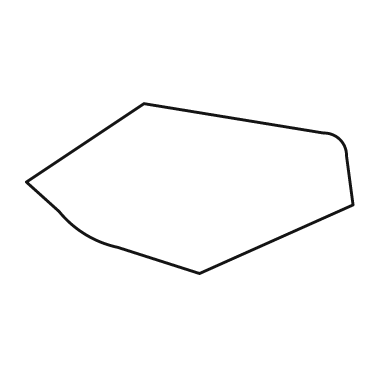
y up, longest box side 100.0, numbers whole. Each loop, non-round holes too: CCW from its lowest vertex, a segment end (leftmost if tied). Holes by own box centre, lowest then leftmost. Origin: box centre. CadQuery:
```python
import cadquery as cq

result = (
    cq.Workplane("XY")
    .moveTo(3.0, -26.0)
    .lineTo(50.0, -5.0)
    .lineTo(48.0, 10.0)
    .threePointArc((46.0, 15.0), (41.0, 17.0))
    .lineTo(-14.0, 26.0)
    .lineTo(-50.0, 2.0)
    .lineTo(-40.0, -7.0)
    .threePointArc((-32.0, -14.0), (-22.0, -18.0))
    .close()
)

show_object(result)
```